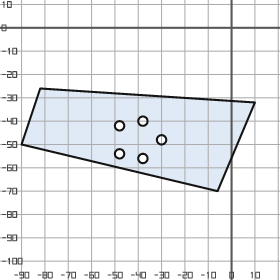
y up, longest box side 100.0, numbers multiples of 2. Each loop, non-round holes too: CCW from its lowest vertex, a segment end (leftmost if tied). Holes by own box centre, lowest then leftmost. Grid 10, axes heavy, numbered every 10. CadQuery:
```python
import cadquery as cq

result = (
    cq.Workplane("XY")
    .moveTo(-6.0, -70.0)
    .lineTo(10.0, -32.0)
    .lineTo(-82.0, -26.0)
    .lineTo(-90.0, -50.0)
    .close()
    .moveTo(-38.0, -56.0)
    .circle(2.0)
    .moveTo(-48.0, -54.0)
    .circle(2.0)
    .moveTo(-30.0, -48.0)
    .circle(2.0)
    .moveTo(-48.0, -42.0)
    .circle(2.0)
    .moveTo(-38.0, -40.0)
    .circle(2.0)
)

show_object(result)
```